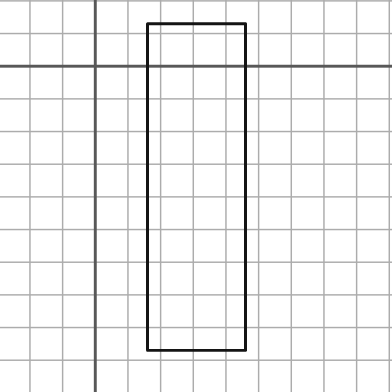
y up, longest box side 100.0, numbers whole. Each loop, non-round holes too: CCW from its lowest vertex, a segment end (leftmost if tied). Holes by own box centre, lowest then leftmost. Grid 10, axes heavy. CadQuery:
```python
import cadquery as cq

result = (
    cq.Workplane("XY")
    .moveTo(16.0, -87.0)
    .lineTo(46.0, -87.0)
    .lineTo(46.0, 13.0)
    .lineTo(16.0, 13.0)
    .close()
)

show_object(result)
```